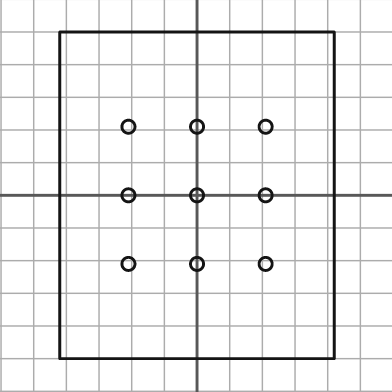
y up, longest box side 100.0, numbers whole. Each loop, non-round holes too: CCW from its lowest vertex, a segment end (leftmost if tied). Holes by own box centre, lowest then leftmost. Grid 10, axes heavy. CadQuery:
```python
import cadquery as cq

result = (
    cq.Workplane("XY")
    .moveTo(-42.0, -50.0)
    .lineTo(42.0, -50.0)
    .lineTo(42.0, 50.0)
    .lineTo(-42.0, 50.0)
    .close()
    .moveTo(-21.0, -21.0)
    .circle(2.0)
    .moveTo(0.0, -21.0)
    .circle(2.0)
    .moveTo(21.0, -21.0)
    .circle(2.0)
    .moveTo(-21.0, 0.0)
    .circle(2.0)
    .moveTo(0.0, 0.0)
    .circle(2.0)
    .moveTo(21.0, 0.0)
    .circle(2.0)
    .moveTo(-21.0, 21.0)
    .circle(2.0)
    .moveTo(0.0, 21.0)
    .circle(2.0)
    .moveTo(21.0, 21.0)
    .circle(2.0)
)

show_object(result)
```